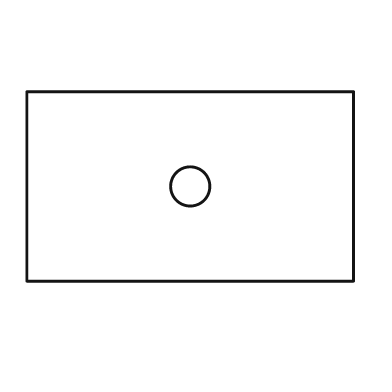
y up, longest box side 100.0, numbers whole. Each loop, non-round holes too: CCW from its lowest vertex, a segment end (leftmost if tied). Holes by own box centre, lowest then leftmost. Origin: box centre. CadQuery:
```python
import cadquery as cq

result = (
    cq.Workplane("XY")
    .moveTo(-50.0, -29.0)
    .lineTo(50.0, -29.0)
    .lineTo(50.0, 29.0)
    .lineTo(-50.0, 29.0)
    .close()
    .moveTo(0.0, 0.0)
    .circle(6.0)
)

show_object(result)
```